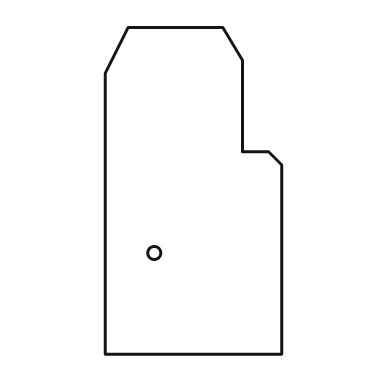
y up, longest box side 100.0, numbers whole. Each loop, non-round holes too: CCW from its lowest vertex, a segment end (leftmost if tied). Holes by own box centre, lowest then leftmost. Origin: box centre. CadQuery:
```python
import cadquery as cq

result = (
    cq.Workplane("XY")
    .moveTo(-27.0, -50.0)
    .lineTo(27.0, -50.0)
    .lineTo(27.0, 8.0)
    .lineTo(23.0, 12.0)
    .lineTo(15.0, 12.0)
    .lineTo(15.0, 40.0)
    .lineTo(9.0, 50.0)
    .lineTo(-20.0, 50.0)
    .lineTo(-27.0, 36.0)
    .close()
    .moveTo(-12.0, -19.0)
    .circle(2.0)
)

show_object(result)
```